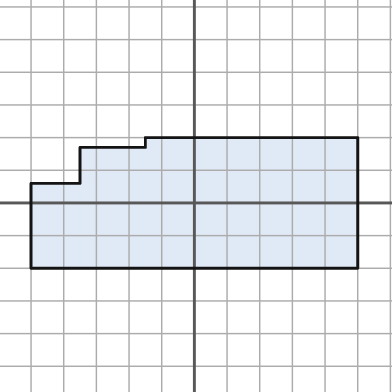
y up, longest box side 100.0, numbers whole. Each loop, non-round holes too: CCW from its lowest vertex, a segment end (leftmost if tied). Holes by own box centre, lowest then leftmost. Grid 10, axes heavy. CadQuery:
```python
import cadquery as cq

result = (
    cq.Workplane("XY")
    .moveTo(-50.0, -20.0)
    .lineTo(50.0, -20.0)
    .lineTo(50.0, 20.0)
    .lineTo(-15.0, 20.0)
    .lineTo(-15.0, 17.0)
    .lineTo(-35.0, 17.0)
    .lineTo(-35.0, 6.0)
    .lineTo(-50.0, 6.0)
    .close()
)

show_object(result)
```